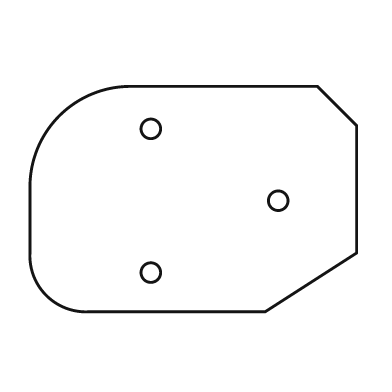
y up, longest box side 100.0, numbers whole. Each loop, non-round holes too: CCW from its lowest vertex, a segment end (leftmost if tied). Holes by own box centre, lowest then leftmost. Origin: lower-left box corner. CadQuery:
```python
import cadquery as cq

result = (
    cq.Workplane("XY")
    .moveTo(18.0, 0.0)
    .lineTo(72.0, 0.0)
    .lineTo(100.0, 18.0)
    .lineTo(100.0, 57.0)
    .lineTo(88.0, 69.0)
    .lineTo(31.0, 69.0)
    .threePointArc((9.0, 60.0), (0.0, 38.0))
    .lineTo(0.0, 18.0)
    .threePointArc((5.0, 5.0), (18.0, 0.0))
    .close()
    .moveTo(37.0, 12.0)
    .circle(3.0)
    .moveTo(76.0, 34.0)
    .circle(3.0)
    .moveTo(37.0, 56.0)
    .circle(3.0)
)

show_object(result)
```